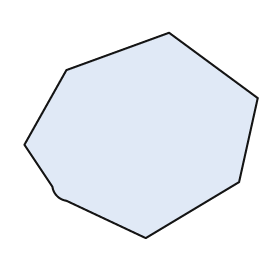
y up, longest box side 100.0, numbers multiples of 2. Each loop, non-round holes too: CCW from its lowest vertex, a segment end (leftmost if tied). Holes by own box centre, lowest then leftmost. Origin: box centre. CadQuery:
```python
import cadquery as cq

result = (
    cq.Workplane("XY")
    .moveTo(2.0, -44.0)
    .lineTo(42.0, -20.0)
    .lineTo(50.0, 16.0)
    .lineTo(12.0, 44.0)
    .lineTo(-32.0, 28.0)
    .lineTo(-50.0, -4.0)
    .lineTo(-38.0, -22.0)
    .threePointArc((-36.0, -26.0), (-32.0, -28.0))
    .close()
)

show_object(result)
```